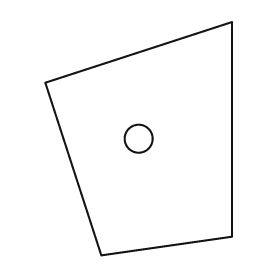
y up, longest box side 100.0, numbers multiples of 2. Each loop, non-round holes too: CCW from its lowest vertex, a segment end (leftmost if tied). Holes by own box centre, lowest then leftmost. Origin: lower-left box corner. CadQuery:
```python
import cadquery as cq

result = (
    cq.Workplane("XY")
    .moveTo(24.0, 0.0)
    .lineTo(80.0, 8.0)
    .lineTo(80.0, 100.0)
    .lineTo(0.0, 74.0)
    .close()
    .moveTo(40.0, 50.0)
    .circle(6.0)
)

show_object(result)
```